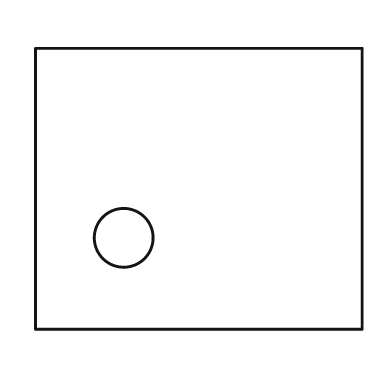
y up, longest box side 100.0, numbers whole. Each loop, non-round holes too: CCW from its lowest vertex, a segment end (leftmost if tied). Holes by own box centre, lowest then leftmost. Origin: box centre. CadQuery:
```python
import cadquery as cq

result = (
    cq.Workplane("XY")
    .moveTo(-50.0, -43.0)
    .lineTo(50.0, -43.0)
    .lineTo(50.0, 43.0)
    .lineTo(-50.0, 43.0)
    .close()
    .moveTo(-23.0, -15.0)
    .circle(9.0)
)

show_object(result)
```